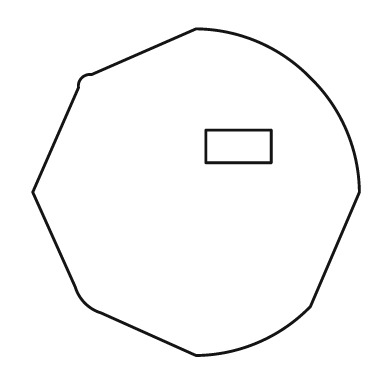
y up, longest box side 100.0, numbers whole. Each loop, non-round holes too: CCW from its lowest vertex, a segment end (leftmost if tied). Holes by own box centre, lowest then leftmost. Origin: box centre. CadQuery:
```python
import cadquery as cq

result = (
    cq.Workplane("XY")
    .moveTo(0.0, -50.0)
    .threePointArc((19.0, -46.0), (35.0, -35.0))
    .lineTo(50.0, 0.0)
    .threePointArc((46.0, 19.0), (35.0, 35.0))
    .threePointArc((19.0, 46.0), (0.0, 50.0))
    .lineTo(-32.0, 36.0)
    .threePointArc((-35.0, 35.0), (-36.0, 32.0))
    .lineTo(-50.0, 0.0)
    .lineTo(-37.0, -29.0)
    .threePointArc((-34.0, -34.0), (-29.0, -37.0))
    .close()
    .moveTo(3.0, 9.0)
    .lineTo(23.0, 9.0)
    .lineTo(23.0, 19.0)
    .lineTo(3.0, 19.0)
    .close()
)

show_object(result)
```